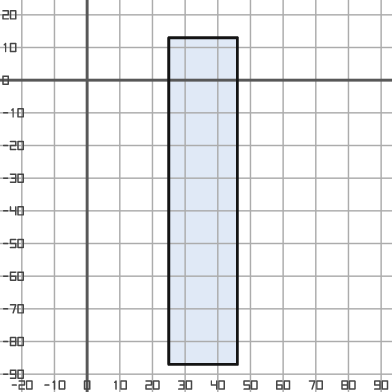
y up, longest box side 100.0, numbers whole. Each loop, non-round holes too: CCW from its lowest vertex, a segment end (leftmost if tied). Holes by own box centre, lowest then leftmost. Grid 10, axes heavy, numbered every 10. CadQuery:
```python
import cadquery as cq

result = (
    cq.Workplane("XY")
    .moveTo(25.0, -87.0)
    .lineTo(46.0, -87.0)
    .lineTo(46.0, 13.0)
    .lineTo(25.0, 13.0)
    .close()
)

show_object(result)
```